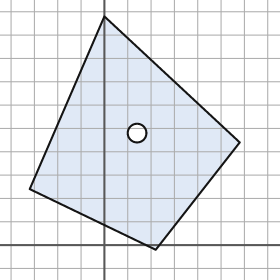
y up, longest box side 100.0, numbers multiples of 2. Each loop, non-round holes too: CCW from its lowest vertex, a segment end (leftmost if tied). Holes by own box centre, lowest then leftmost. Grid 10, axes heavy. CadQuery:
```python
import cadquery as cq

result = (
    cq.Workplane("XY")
    .moveTo(22.0, -2.0)
    .lineTo(58.0, 44.0)
    .lineTo(0.0, 98.0)
    .lineTo(-32.0, 24.0)
    .close()
    .moveTo(14.0, 48.0)
    .circle(4.0)
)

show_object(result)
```